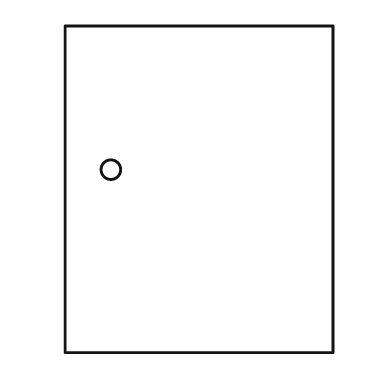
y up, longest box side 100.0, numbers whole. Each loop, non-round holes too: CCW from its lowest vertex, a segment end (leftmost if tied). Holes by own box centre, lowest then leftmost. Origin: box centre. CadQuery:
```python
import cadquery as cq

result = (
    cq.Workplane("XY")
    .moveTo(-41.0, -50.0)
    .lineTo(41.0, -50.0)
    .lineTo(41.0, 50.0)
    .lineTo(-41.0, 50.0)
    .close()
    .moveTo(-27.0, 6.0)
    .circle(3.0)
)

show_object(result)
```